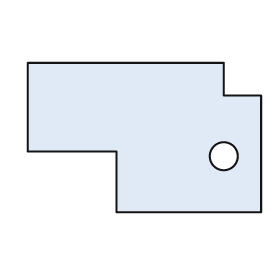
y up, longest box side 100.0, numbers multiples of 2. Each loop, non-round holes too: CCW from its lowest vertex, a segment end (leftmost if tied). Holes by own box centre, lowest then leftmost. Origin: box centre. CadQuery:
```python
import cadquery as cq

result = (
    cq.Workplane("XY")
    .moveTo(-12.0, -32.0)
    .lineTo(50.0, -32.0)
    .lineTo(50.0, 18.0)
    .lineTo(34.0, 18.0)
    .lineTo(34.0, 32.0)
    .lineTo(-50.0, 32.0)
    .lineTo(-50.0, -6.0)
    .lineTo(-12.0, -6.0)
    .close()
    .moveTo(34.0, -8.0)
    .circle(6.0)
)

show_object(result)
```